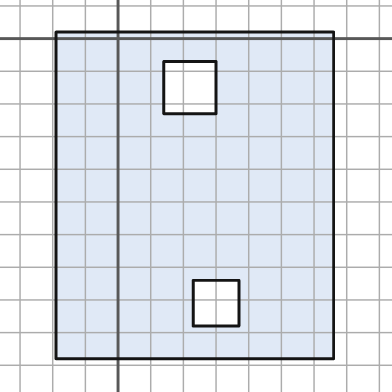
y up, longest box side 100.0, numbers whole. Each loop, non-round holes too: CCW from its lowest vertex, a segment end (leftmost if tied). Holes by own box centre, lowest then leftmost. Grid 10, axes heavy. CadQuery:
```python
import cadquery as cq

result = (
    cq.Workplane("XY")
    .moveTo(-19.0, -98.0)
    .lineTo(66.0, -98.0)
    .lineTo(66.0, 2.0)
    .lineTo(-19.0, 2.0)
    .close()
    .moveTo(23.0, -88.0)
    .lineTo(37.0, -88.0)
    .lineTo(37.0, -74.0)
    .lineTo(23.0, -74.0)
    .close()
    .moveTo(14.0, -23.0)
    .lineTo(30.0, -23.0)
    .lineTo(30.0, -7.0)
    .lineTo(14.0, -7.0)
    .close()
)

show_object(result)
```